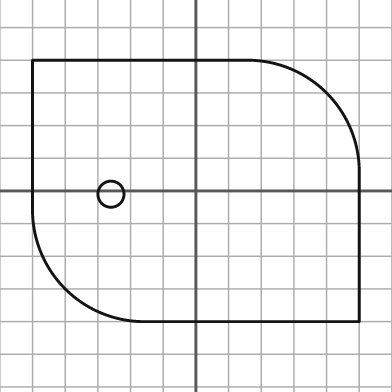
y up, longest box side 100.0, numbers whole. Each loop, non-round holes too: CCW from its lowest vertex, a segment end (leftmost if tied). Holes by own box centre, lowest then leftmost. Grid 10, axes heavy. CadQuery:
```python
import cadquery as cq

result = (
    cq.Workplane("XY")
    .moveTo(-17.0, -40.0)
    .lineTo(50.0, -40.0)
    .lineTo(50.0, 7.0)
    .threePointArc((40.0, 30.0), (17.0, 40.0))
    .lineTo(-50.0, 40.0)
    .lineTo(-50.0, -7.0)
    .threePointArc((-40.0, -30.0), (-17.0, -40.0))
    .close()
    .moveTo(-26.0, -1.0)
    .circle(4.0)
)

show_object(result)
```